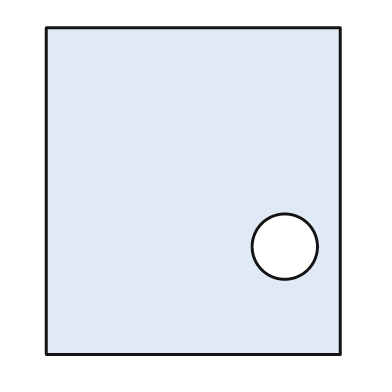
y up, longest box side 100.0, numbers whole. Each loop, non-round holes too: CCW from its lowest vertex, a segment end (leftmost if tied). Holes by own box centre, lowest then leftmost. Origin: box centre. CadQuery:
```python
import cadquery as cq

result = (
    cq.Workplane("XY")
    .moveTo(-45.0, -50.0)
    .lineTo(45.0, -50.0)
    .lineTo(45.0, 50.0)
    .lineTo(-45.0, 50.0)
    .close()
    .moveTo(28.0, -17.0)
    .circle(10.0)
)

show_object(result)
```